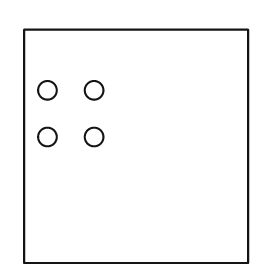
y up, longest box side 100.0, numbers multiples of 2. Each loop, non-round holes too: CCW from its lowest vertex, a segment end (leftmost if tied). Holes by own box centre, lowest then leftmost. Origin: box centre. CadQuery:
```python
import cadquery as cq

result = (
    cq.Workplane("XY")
    .moveTo(-48.0, -50.0)
    .lineTo(48.0, -50.0)
    .lineTo(48.0, 50.0)
    .lineTo(-48.0, 50.0)
    .close()
    .moveTo(-38.0, 4.0)
    .circle(4.0)
    .moveTo(-18.0, 4.0)
    .circle(4.0)
    .moveTo(-38.0, 24.0)
    .circle(4.0)
    .moveTo(-18.0, 24.0)
    .circle(4.0)
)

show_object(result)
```